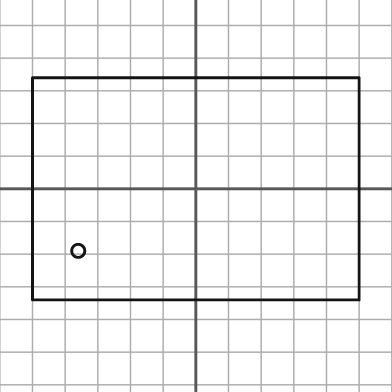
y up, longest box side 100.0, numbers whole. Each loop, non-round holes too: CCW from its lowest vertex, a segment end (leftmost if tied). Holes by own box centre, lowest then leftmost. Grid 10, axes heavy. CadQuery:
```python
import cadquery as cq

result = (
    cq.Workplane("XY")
    .moveTo(-50.0, -34.0)
    .lineTo(50.0, -34.0)
    .lineTo(50.0, 34.0)
    .lineTo(-50.0, 34.0)
    .close()
    .moveTo(-36.0, -19.0)
    .circle(2.0)
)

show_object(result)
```